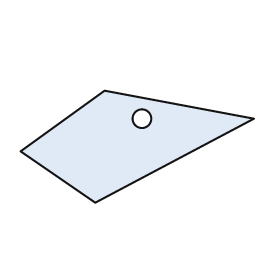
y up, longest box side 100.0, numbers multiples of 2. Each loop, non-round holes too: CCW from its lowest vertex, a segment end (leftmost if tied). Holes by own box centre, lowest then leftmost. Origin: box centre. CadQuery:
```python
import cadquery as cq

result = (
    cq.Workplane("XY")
    .moveTo(-18.0, -24.0)
    .lineTo(50.0, 12.0)
    .lineTo(-14.0, 24.0)
    .lineTo(-50.0, -2.0)
    .close()
    .moveTo(2.0, 12.0)
    .circle(4.0)
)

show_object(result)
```